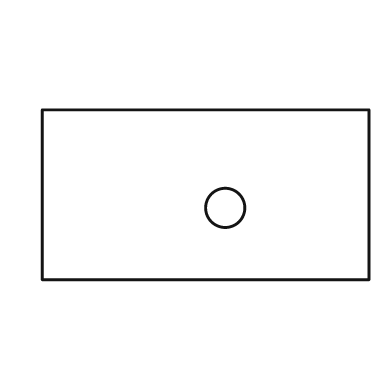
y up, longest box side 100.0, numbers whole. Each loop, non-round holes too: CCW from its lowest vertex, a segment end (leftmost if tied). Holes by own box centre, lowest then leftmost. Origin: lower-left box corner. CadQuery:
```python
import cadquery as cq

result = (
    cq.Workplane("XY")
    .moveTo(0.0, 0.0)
    .lineTo(100.0, 0.0)
    .lineTo(100.0, 52.0)
    .lineTo(0.0, 52.0)
    .close()
    .moveTo(56.0, 22.0)
    .circle(6.0)
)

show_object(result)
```